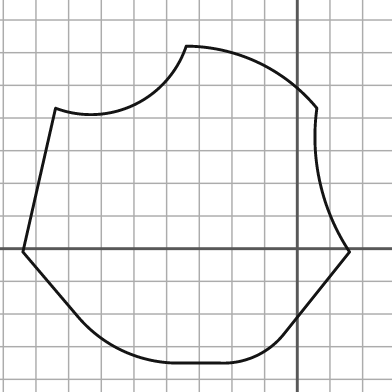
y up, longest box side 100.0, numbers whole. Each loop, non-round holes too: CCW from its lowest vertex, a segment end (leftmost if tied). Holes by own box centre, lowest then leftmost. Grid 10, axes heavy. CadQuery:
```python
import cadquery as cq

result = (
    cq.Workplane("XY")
    .moveTo(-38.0, -35.0)
    .lineTo(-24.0, -35.0)
    .threePointArc((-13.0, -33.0), (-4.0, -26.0))
    .lineTo(16.0, -1.0)
    .threePointArc((7.0, 20.0), (6.0, 43.0))
    .threePointArc((-12.0, 57.0), (-34.0, 62.0))
    .threePointArc((-50.0, 44.0), (-74.0, 43.0))
    .lineTo(-84.0, -1.0)
    .lineTo(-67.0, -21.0)
    .threePointArc((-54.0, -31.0), (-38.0, -35.0))
    .close()
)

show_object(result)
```